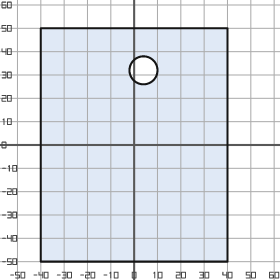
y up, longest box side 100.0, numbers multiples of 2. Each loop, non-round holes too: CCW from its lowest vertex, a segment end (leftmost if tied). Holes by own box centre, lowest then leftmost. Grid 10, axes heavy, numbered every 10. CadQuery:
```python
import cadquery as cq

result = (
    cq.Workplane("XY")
    .moveTo(-40.0, -50.0)
    .lineTo(40.0, -50.0)
    .lineTo(40.0, 50.0)
    .lineTo(-40.0, 50.0)
    .close()
    .moveTo(4.0, 32.0)
    .circle(6.0)
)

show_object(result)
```